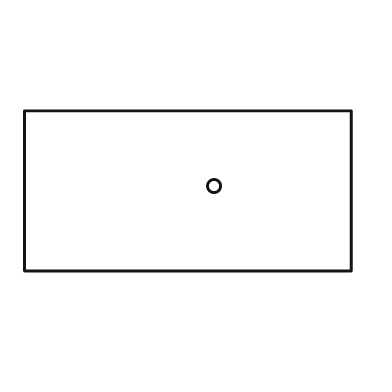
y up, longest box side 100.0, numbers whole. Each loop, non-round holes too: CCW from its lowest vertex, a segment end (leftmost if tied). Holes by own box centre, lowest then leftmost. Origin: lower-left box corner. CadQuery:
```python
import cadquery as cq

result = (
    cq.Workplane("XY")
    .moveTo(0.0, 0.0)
    .lineTo(100.0, 0.0)
    .lineTo(100.0, 49.0)
    .lineTo(0.0, 49.0)
    .close()
    .moveTo(58.0, 26.0)
    .circle(2.0)
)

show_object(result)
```